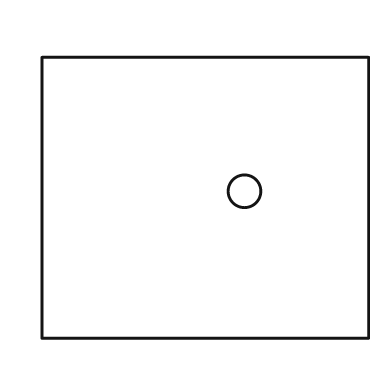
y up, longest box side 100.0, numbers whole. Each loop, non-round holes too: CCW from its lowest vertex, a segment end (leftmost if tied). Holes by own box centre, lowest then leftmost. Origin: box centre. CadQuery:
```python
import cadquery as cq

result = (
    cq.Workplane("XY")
    .moveTo(-50.0, -43.0)
    .lineTo(50.0, -43.0)
    .lineTo(50.0, 43.0)
    .lineTo(-50.0, 43.0)
    .close()
    .moveTo(12.0, 2.0)
    .circle(5.0)
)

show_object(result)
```